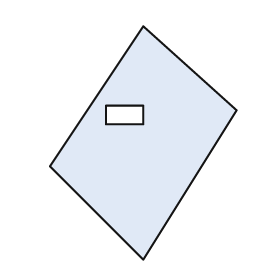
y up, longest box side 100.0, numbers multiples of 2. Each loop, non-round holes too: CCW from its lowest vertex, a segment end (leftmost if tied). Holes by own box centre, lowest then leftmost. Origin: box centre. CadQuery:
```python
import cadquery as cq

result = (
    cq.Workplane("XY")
    .moveTo(0.0, -50.0)
    .lineTo(40.0, 14.0)
    .lineTo(0.0, 50.0)
    .lineTo(-40.0, -10.0)
    .close()
    .moveTo(-16.0, 8.0)
    .lineTo(0.0, 8.0)
    .lineTo(0.0, 16.0)
    .lineTo(-16.0, 16.0)
    .close()
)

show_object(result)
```